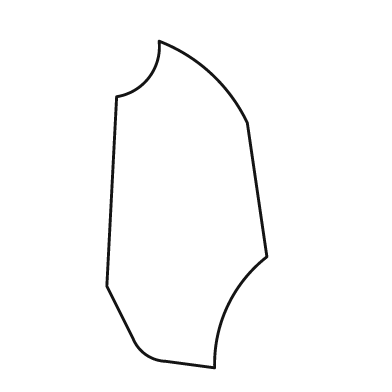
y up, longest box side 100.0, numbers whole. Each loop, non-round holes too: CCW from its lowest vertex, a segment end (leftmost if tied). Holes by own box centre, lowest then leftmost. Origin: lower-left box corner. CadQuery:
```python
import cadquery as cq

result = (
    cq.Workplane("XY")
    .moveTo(33.0, 0.0)
    .threePointArc((37.0, 19.0), (49.0, 34.0))
    .lineTo(43.0, 75.0)
    .threePointArc((32.0, 90.0), (16.0, 100.0))
    .threePointArc((13.0, 89.0), (3.0, 83.0))
    .lineTo(0.0, 25.0)
    .lineTo(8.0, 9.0)
    .threePointArc((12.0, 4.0), (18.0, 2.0))
    .close()
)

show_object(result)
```